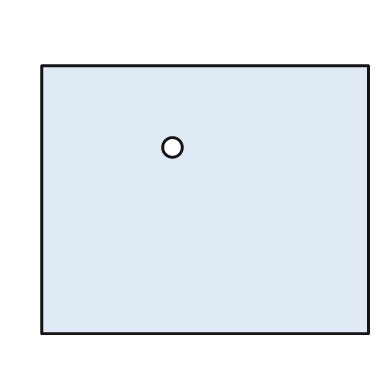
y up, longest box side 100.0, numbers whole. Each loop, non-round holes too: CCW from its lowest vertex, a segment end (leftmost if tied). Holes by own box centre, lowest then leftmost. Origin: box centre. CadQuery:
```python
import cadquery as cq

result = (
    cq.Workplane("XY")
    .moveTo(-50.0, -41.0)
    .lineTo(50.0, -41.0)
    .lineTo(50.0, 41.0)
    .lineTo(-50.0, 41.0)
    .close()
    .moveTo(-10.0, 16.0)
    .circle(3.0)
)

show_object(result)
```